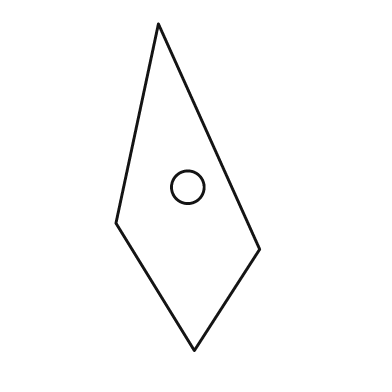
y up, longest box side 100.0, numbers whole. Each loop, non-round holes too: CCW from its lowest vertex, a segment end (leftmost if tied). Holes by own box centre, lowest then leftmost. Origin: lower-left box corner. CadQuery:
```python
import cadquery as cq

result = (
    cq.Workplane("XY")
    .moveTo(24.0, 0.0)
    .lineTo(44.0, 31.0)
    .lineTo(13.0, 100.0)
    .lineTo(0.0, 39.0)
    .close()
    .moveTo(22.0, 50.0)
    .circle(5.0)
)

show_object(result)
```